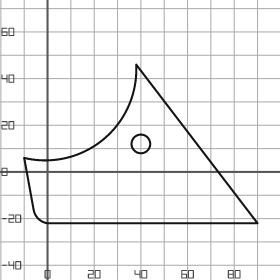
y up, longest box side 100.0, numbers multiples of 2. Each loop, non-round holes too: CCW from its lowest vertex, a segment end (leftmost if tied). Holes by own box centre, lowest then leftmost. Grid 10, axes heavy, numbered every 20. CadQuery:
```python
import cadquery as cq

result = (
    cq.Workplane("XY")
    .moveTo(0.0, -22.0)
    .lineTo(90.0, -22.0)
    .lineTo(38.0, 46.0)
    .threePointArc((24.0, 14.0), (-10.0, 6.0))
    .lineTo(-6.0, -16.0)
    .threePointArc((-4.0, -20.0), (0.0, -22.0))
    .close()
    .moveTo(40.0, 12.0)
    .circle(4.0)
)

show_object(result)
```